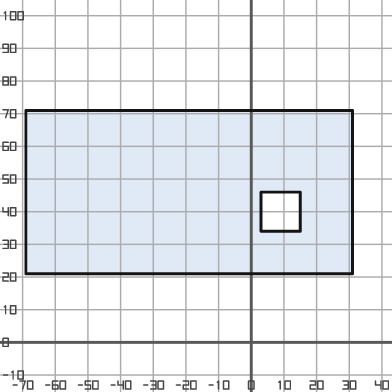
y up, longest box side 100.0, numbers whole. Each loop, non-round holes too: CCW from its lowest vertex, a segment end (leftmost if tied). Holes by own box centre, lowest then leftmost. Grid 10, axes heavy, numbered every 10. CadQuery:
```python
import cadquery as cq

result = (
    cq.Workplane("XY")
    .moveTo(-69.0, 21.0)
    .lineTo(31.0, 21.0)
    .lineTo(31.0, 71.0)
    .lineTo(-69.0, 71.0)
    .close()
    .moveTo(3.0, 34.0)
    .lineTo(15.0, 34.0)
    .lineTo(15.0, 46.0)
    .lineTo(3.0, 46.0)
    .close()
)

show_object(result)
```